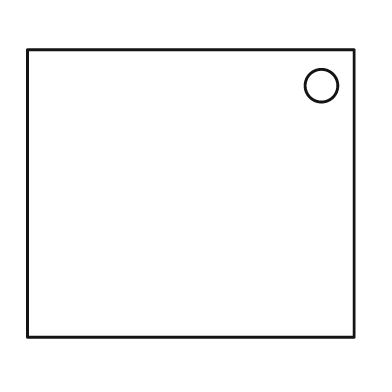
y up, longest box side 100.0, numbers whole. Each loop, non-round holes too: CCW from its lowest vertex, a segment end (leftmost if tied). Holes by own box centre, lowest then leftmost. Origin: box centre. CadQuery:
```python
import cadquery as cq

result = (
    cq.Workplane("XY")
    .moveTo(-50.0, -44.0)
    .lineTo(50.0, -44.0)
    .lineTo(50.0, 44.0)
    .lineTo(-50.0, 44.0)
    .close()
    .moveTo(40.0, 33.0)
    .circle(5.0)
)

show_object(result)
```